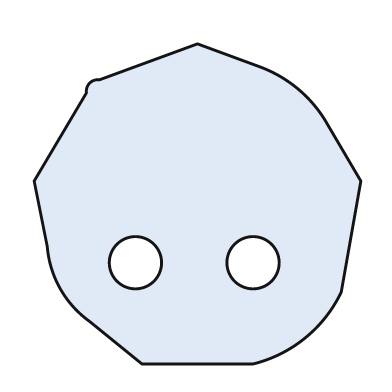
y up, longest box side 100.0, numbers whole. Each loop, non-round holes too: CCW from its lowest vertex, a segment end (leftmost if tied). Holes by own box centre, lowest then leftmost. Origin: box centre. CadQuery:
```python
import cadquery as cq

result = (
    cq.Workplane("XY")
    .moveTo(-17.0, -49.0)
    .lineTo(17.0, -49.0)
    .threePointArc((33.0, -41.0), (44.0, -27.0))
    .lineTo(50.0, 7.0)
    .lineTo(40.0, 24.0)
    .threePointArc((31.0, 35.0), (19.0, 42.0))
    .lineTo(0.0, 49.0)
    .lineTo(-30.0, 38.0)
    .threePointArc((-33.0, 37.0), (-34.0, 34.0))
    .lineTo(-50.0, 7.0)
    .lineTo(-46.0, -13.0)
    .threePointArc((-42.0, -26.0), (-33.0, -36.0))
    .close()
    .moveTo(-19.0, -18.0)
    .circle(8.0)
    .moveTo(17.0, -18.0)
    .circle(8.0)
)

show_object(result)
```